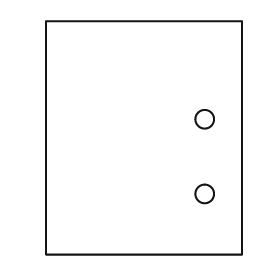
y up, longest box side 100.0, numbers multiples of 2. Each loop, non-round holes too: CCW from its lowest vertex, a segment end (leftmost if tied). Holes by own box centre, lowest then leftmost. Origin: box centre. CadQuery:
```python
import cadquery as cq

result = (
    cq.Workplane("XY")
    .moveTo(-42.0, -50.0)
    .lineTo(42.0, -50.0)
    .lineTo(42.0, 50.0)
    .lineTo(-42.0, 50.0)
    .close()
    .moveTo(26.0, -24.0)
    .circle(4.0)
    .moveTo(26.0, 8.0)
    .circle(4.0)
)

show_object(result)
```